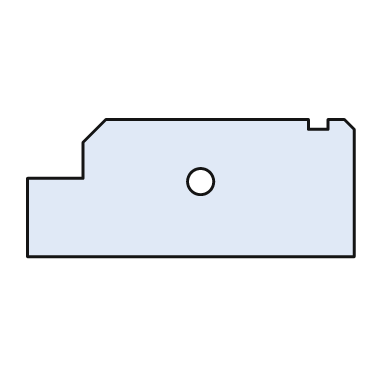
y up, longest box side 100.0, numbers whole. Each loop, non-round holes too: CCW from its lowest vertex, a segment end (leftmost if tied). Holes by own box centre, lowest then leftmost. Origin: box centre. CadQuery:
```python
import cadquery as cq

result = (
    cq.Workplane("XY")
    .moveTo(-50.0, -21.0)
    .lineTo(50.0, -21.0)
    .lineTo(50.0, 18.0)
    .lineTo(47.0, 21.0)
    .lineTo(42.0, 21.0)
    .lineTo(42.0, 18.0)
    .lineTo(36.0, 18.0)
    .lineTo(36.0, 21.0)
    .lineTo(-26.0, 21.0)
    .lineTo(-33.0, 14.0)
    .lineTo(-33.0, 3.0)
    .lineTo(-50.0, 3.0)
    .close()
    .moveTo(3.0, 2.0)
    .circle(4.0)
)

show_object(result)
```